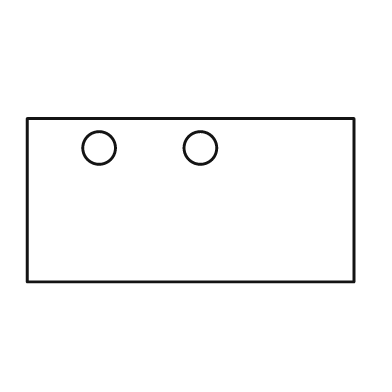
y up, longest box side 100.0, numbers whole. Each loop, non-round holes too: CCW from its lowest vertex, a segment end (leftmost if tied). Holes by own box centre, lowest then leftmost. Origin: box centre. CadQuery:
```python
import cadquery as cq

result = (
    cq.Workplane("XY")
    .moveTo(-50.0, -25.0)
    .lineTo(50.0, -25.0)
    .lineTo(50.0, 25.0)
    .lineTo(-50.0, 25.0)
    .close()
    .moveTo(-28.0, 16.0)
    .circle(5.0)
    .moveTo(3.0, 16.0)
    .circle(5.0)
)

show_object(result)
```